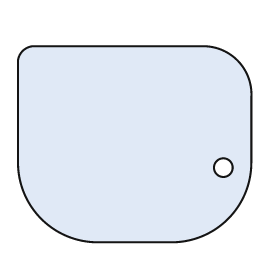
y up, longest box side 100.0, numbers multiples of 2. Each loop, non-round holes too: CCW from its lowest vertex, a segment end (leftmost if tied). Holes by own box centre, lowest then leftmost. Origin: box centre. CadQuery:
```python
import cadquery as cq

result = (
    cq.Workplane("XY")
    .moveTo(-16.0, -42.0)
    .lineTo(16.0, -42.0)
    .threePointArc((40.0, -32.0), (50.0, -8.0))
    .lineTo(50.0, 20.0)
    .threePointArc((44.0, 36.0), (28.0, 42.0))
    .lineTo(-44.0, 42.0)
    .threePointArc((-48.0, 40.0), (-50.0, 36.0))
    .lineTo(-50.0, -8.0)
    .threePointArc((-40.0, -32.0), (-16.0, -42.0))
    .close()
    .moveTo(38.0, -10.0)
    .circle(4.0)
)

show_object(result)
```